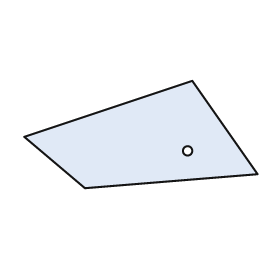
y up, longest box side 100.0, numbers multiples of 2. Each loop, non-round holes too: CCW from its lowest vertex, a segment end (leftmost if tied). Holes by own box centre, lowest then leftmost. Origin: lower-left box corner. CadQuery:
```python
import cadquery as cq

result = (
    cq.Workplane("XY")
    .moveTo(26.0, 0.0)
    .lineTo(100.0, 6.0)
    .lineTo(72.0, 46.0)
    .lineTo(0.0, 22.0)
    .close()
    .moveTo(70.0, 16.0)
    .circle(2.0)
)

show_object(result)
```